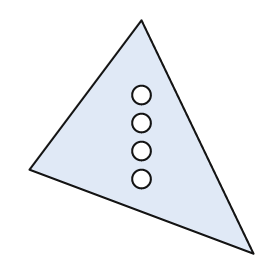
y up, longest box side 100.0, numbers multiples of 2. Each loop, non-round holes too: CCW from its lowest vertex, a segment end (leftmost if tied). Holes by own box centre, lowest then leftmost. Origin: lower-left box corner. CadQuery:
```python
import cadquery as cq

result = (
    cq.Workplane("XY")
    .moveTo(96.0, 0.0)
    .lineTo(48.0, 100.0)
    .lineTo(0.0, 36.0)
    .close()
    .moveTo(48.0, 32.0)
    .circle(4.0)
    .moveTo(48.0, 44.0)
    .circle(4.0)
    .moveTo(48.0, 56.0)
    .circle(4.0)
    .moveTo(48.0, 68.0)
    .circle(4.0)
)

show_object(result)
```